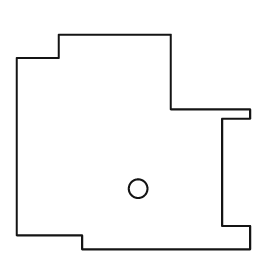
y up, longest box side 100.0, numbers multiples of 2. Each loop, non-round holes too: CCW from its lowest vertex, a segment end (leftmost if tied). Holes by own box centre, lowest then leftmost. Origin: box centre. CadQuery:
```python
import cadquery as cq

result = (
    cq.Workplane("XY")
    .moveTo(-22.0, -46.0)
    .lineTo(50.0, -46.0)
    .lineTo(50.0, -36.0)
    .lineTo(38.0, -36.0)
    .lineTo(38.0, 10.0)
    .lineTo(50.0, 10.0)
    .lineTo(50.0, 14.0)
    .lineTo(16.0, 14.0)
    .lineTo(16.0, 46.0)
    .lineTo(-32.0, 46.0)
    .lineTo(-32.0, 36.0)
    .lineTo(-50.0, 36.0)
    .lineTo(-50.0, -40.0)
    .lineTo(-22.0, -40.0)
    .close()
    .moveTo(2.0, -20.0)
    .circle(4.0)
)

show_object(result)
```